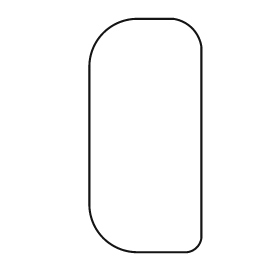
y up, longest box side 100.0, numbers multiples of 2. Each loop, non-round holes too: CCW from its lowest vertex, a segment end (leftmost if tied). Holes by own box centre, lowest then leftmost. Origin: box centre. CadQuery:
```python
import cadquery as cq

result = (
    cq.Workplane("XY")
    .moveTo(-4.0, -50.0)
    .lineTo(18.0, -50.0)
    .threePointArc((22.0, -48.0), (24.0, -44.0))
    .lineTo(24.0, 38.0)
    .threePointArc((20.0, 46.0), (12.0, 50.0))
    .lineTo(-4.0, 50.0)
    .threePointArc((-18.0, 44.0), (-24.0, 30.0))
    .lineTo(-24.0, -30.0)
    .threePointArc((-18.0, -44.0), (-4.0, -50.0))
    .close()
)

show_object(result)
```